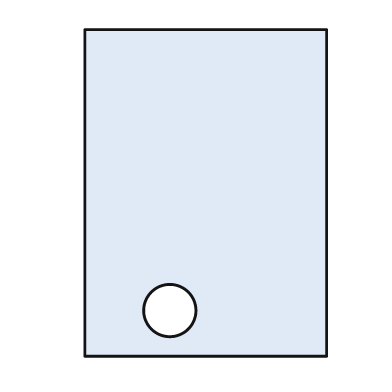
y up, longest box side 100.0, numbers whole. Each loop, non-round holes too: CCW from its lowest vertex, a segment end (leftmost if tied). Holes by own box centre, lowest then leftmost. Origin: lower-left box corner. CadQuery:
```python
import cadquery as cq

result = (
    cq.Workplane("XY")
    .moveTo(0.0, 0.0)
    .lineTo(74.0, 0.0)
    .lineTo(74.0, 100.0)
    .lineTo(0.0, 100.0)
    .close()
    .moveTo(26.0, 14.0)
    .circle(8.0)
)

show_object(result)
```